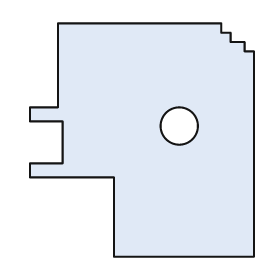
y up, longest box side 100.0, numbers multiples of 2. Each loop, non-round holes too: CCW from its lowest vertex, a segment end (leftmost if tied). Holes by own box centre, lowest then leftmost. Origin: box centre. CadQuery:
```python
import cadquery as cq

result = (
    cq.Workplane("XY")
    .moveTo(-12.0, -50.0)
    .lineTo(48.0, -50.0)
    .lineTo(48.0, 38.0)
    .lineTo(44.0, 38.0)
    .lineTo(44.0, 42.0)
    .lineTo(38.0, 42.0)
    .lineTo(38.0, 46.0)
    .lineTo(34.0, 46.0)
    .lineTo(34.0, 50.0)
    .lineTo(-36.0, 50.0)
    .lineTo(-36.0, 14.0)
    .lineTo(-48.0, 14.0)
    .lineTo(-48.0, 8.0)
    .lineTo(-34.0, 8.0)
    .lineTo(-34.0, -10.0)
    .lineTo(-48.0, -10.0)
    .lineTo(-48.0, -16.0)
    .lineTo(-12.0, -16.0)
    .close()
    .moveTo(16.0, 6.0)
    .circle(8.0)
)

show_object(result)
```